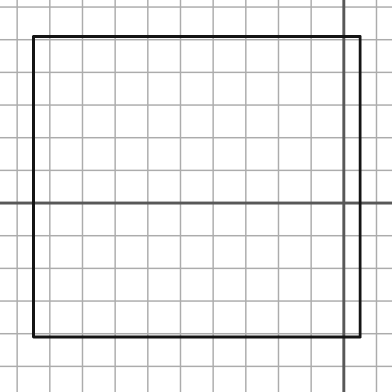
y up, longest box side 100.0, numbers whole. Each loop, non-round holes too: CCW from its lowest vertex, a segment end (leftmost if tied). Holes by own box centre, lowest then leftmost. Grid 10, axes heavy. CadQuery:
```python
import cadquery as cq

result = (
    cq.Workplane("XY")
    .moveTo(-95.0, -41.0)
    .lineTo(5.0, -41.0)
    .lineTo(5.0, 51.0)
    .lineTo(-95.0, 51.0)
    .close()
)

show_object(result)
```